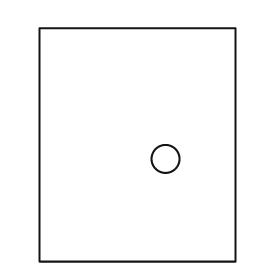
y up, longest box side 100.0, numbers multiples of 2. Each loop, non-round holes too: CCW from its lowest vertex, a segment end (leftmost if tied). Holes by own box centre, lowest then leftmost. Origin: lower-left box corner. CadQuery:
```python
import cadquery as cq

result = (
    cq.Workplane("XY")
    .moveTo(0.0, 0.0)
    .lineTo(84.0, 0.0)
    .lineTo(84.0, 100.0)
    .lineTo(0.0, 100.0)
    .close()
    .moveTo(54.0, 44.0)
    .circle(6.0)
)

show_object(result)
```